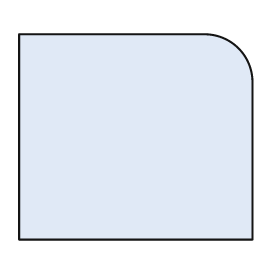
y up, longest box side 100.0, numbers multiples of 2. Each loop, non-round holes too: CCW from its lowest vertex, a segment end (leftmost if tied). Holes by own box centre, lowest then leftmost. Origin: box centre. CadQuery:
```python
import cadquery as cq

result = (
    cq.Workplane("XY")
    .moveTo(-50.0, -44.0)
    .lineTo(50.0, -44.0)
    .lineTo(50.0, 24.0)
    .threePointArc((44.0, 38.0), (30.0, 44.0))
    .lineTo(-50.0, 44.0)
    .close()
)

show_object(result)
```